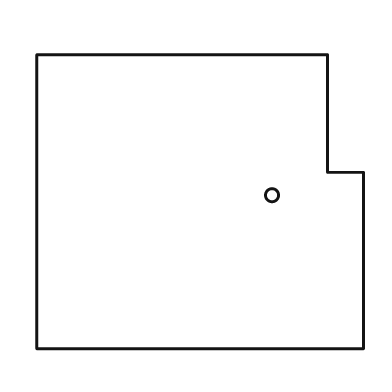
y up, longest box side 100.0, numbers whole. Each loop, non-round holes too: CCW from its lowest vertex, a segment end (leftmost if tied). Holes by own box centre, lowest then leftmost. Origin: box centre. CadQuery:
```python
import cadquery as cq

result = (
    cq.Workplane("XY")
    .moveTo(-50.0, -45.0)
    .lineTo(50.0, -45.0)
    .lineTo(50.0, 9.0)
    .lineTo(39.0, 9.0)
    .lineTo(39.0, 45.0)
    .lineTo(-50.0, 45.0)
    .close()
    .moveTo(22.0, 2.0)
    .circle(2.0)
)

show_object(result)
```